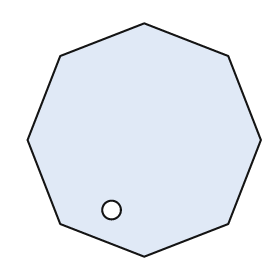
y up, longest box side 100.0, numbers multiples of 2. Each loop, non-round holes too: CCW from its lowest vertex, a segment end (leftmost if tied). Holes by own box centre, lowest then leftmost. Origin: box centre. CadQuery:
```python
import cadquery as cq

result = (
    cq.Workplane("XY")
    .moveTo(0.0, -50.0)
    .lineTo(36.0, -36.0)
    .lineTo(50.0, 0.0)
    .lineTo(36.0, 36.0)
    .lineTo(0.0, 50.0)
    .lineTo(-36.0, 36.0)
    .lineTo(-50.0, 0.0)
    .lineTo(-36.0, -36.0)
    .close()
    .moveTo(-14.0, -30.0)
    .circle(4.0)
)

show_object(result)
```